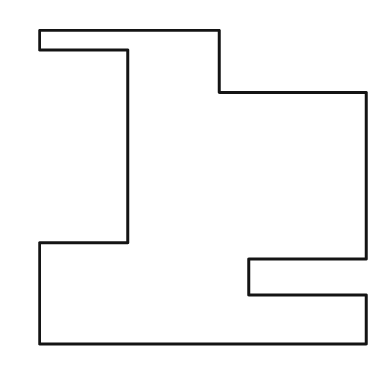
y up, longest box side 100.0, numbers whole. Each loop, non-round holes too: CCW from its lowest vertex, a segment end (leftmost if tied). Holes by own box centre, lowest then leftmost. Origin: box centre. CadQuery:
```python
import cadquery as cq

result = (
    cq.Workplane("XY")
    .moveTo(-50.0, -48.0)
    .lineTo(50.0, -48.0)
    .lineTo(50.0, -33.0)
    .lineTo(14.0, -33.0)
    .lineTo(14.0, -22.0)
    .lineTo(50.0, -22.0)
    .lineTo(50.0, 29.0)
    .lineTo(5.0, 29.0)
    .lineTo(5.0, 48.0)
    .lineTo(-50.0, 48.0)
    .lineTo(-50.0, 42.0)
    .lineTo(-23.0, 42.0)
    .lineTo(-23.0, -17.0)
    .lineTo(-50.0, -17.0)
    .close()
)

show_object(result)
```